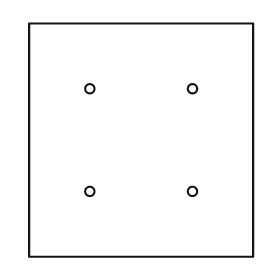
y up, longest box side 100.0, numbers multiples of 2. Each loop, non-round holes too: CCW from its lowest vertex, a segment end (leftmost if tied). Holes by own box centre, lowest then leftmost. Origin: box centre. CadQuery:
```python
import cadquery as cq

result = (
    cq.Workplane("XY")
    .moveTo(-48.0, -50.0)
    .lineTo(48.0, -50.0)
    .lineTo(48.0, 50.0)
    .lineTo(-48.0, 50.0)
    .close()
    .moveTo(-22.0, -22.0)
    .circle(2.0)
    .moveTo(22.0, -22.0)
    .circle(2.0)
    .moveTo(-22.0, 22.0)
    .circle(2.0)
    .moveTo(22.0, 22.0)
    .circle(2.0)
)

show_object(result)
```